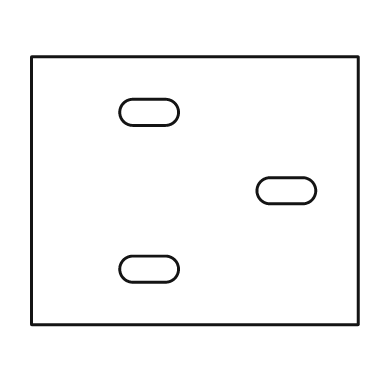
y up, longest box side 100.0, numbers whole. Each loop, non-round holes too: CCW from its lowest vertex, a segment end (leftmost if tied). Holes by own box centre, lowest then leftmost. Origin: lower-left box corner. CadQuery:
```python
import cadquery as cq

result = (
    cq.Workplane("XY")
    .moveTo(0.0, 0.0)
    .lineTo(100.0, 0.0)
    .lineTo(100.0, 82.0)
    .lineTo(0.0, 82.0)
    .close()
    .moveTo(31.0, 13.0)
    .lineTo(41.0, 13.0)
    .threePointArc((45.0, 17.0), (41.0, 21.0))
    .lineTo(31.0, 21.0)
    .threePointArc((27.0, 17.0), (31.0, 13.0))
    .close()
    .moveTo(73.0, 37.0)
    .lineTo(83.0, 37.0)
    .threePointArc((87.0, 41.0), (83.0, 45.0))
    .lineTo(73.0, 45.0)
    .threePointArc((69.0, 41.0), (73.0, 37.0))
    .close()
    .moveTo(31.0, 61.0)
    .lineTo(41.0, 61.0)
    .threePointArc((45.0, 65.0), (41.0, 69.0))
    .lineTo(31.0, 69.0)
    .threePointArc((27.0, 65.0), (31.0, 61.0))
    .close()
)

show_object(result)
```